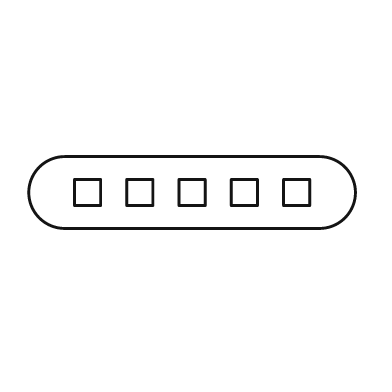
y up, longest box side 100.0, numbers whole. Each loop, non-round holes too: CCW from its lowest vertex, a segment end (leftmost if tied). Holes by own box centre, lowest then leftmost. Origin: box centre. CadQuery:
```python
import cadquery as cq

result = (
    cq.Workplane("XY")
    .moveTo(-39.0, -11.0)
    .lineTo(39.0, -11.0)
    .threePointArc((50.0, 0.0), (39.0, 11.0))
    .lineTo(-39.0, 11.0)
    .threePointArc((-50.0, 0.0), (-39.0, -11.0))
    .close()
    .moveTo(-36.0, -4.0)
    .lineTo(-28.0, -4.0)
    .lineTo(-28.0, 4.0)
    .lineTo(-36.0, 4.0)
    .close()
    .moveTo(-20.0, -4.0)
    .lineTo(-12.0, -4.0)
    .lineTo(-12.0, 4.0)
    .lineTo(-20.0, 4.0)
    .close()
    .moveTo(-4.0, -4.0)
    .lineTo(4.0, -4.0)
    .lineTo(4.0, 4.0)
    .lineTo(-4.0, 4.0)
    .close()
    .moveTo(12.0, -4.0)
    .lineTo(20.0, -4.0)
    .lineTo(20.0, 4.0)
    .lineTo(12.0, 4.0)
    .close()
    .moveTo(28.0, -4.0)
    .lineTo(36.0, -4.0)
    .lineTo(36.0, 4.0)
    .lineTo(28.0, 4.0)
    .close()
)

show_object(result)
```